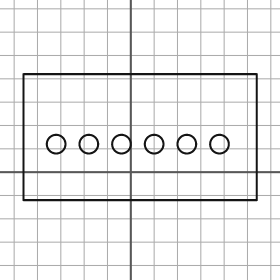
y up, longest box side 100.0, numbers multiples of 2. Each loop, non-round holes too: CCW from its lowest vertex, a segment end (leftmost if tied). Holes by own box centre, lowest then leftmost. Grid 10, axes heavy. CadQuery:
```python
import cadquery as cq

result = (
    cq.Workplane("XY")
    .moveTo(-46.0, -12.0)
    .lineTo(54.0, -12.0)
    .lineTo(54.0, 42.0)
    .lineTo(-46.0, 42.0)
    .close()
    .moveTo(-32.0, 12.0)
    .circle(4.0)
    .moveTo(-18.0, 12.0)
    .circle(4.0)
    .moveTo(-4.0, 12.0)
    .circle(4.0)
    .moveTo(10.0, 12.0)
    .circle(4.0)
    .moveTo(24.0, 12.0)
    .circle(4.0)
    .moveTo(38.0, 12.0)
    .circle(4.0)
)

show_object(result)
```